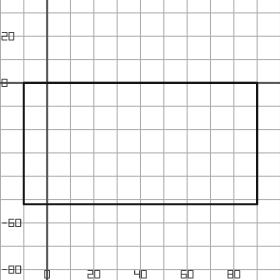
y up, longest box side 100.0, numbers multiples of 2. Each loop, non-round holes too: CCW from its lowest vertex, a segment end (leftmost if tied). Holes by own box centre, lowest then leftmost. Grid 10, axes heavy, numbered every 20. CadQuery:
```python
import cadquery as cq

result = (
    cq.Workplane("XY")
    .moveTo(-10.0, -52.0)
    .lineTo(90.0, -52.0)
    .lineTo(90.0, 0.0)
    .lineTo(-10.0, 0.0)
    .close()
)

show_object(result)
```